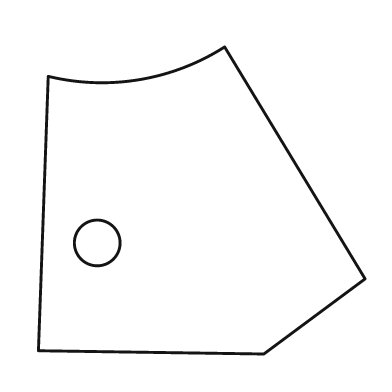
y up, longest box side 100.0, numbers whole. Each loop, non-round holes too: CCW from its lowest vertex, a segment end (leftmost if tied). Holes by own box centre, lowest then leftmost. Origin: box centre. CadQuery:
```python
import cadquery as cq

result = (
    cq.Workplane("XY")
    .moveTo(19.0, -47.0)
    .lineTo(50.0, -24.0)
    .lineTo(7.0, 47.0)
    .threePointArc((-19.0, 37.0), (-47.0, 38.0))
    .lineTo(-50.0, -46.0)
    .close()
    .moveTo(-32.0, -13.0)
    .circle(7.0)
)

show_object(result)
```